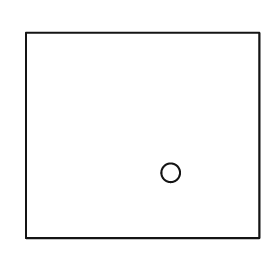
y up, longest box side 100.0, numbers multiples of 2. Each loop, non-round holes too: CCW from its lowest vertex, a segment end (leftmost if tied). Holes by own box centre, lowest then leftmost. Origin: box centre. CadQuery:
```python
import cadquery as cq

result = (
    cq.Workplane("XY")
    .moveTo(-50.0, -44.0)
    .lineTo(50.0, -44.0)
    .lineTo(50.0, 44.0)
    .lineTo(-50.0, 44.0)
    .close()
    .moveTo(12.0, -16.0)
    .circle(4.0)
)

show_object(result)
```